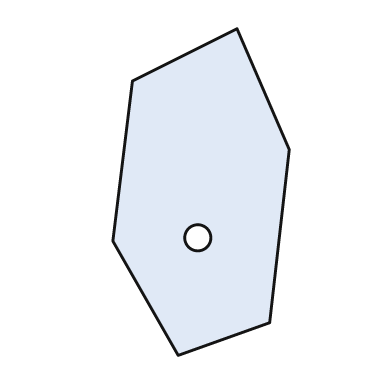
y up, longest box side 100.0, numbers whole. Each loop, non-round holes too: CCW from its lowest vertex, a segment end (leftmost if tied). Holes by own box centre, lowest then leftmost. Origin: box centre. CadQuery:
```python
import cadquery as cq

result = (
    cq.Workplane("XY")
    .moveTo(-7.0, -50.0)
    .lineTo(21.0, -40.0)
    .lineTo(27.0, 13.0)
    .lineTo(11.0, 50.0)
    .lineTo(-21.0, 34.0)
    .lineTo(-27.0, -15.0)
    .close()
    .moveTo(-1.0, -14.0)
    .circle(4.0)
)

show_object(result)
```